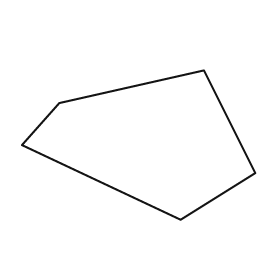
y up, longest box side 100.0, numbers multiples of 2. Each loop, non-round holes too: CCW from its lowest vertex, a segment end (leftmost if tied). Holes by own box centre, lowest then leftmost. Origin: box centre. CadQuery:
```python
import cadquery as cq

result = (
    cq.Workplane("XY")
    .moveTo(18.0, -32.0)
    .lineTo(50.0, -12.0)
    .lineTo(28.0, 32.0)
    .lineTo(-34.0, 18.0)
    .lineTo(-50.0, 0.0)
    .close()
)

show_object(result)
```